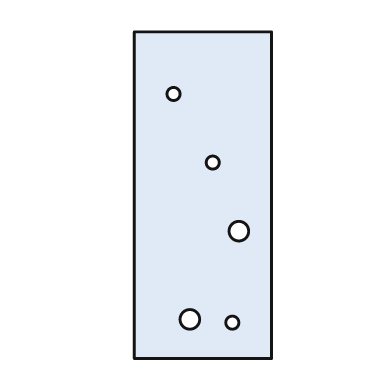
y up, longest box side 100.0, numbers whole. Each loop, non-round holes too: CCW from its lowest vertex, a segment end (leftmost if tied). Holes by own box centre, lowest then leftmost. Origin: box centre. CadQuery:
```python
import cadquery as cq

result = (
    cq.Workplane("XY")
    .moveTo(-21.0, -50.0)
    .lineTo(21.0, -50.0)
    .lineTo(21.0, 50.0)
    .lineTo(-21.0, 50.0)
    .close()
    .moveTo(9.0, -39.0)
    .circle(2.0)
    .moveTo(-4.0, -38.0)
    .circle(3.0)
    .moveTo(11.0, -11.0)
    .circle(3.0)
    .moveTo(3.0, 10.0)
    .circle(2.0)
    .moveTo(-9.0, 31.0)
    .circle(2.0)
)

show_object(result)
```